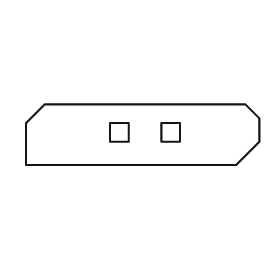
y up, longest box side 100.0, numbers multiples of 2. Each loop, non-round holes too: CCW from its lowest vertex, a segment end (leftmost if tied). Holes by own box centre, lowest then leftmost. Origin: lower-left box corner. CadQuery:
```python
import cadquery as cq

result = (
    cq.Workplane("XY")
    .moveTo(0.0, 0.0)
    .lineTo(90.0, 0.0)
    .lineTo(100.0, 10.0)
    .lineTo(100.0, 20.0)
    .lineTo(94.0, 26.0)
    .lineTo(8.0, 26.0)
    .lineTo(0.0, 18.0)
    .close()
    .moveTo(36.0, 10.0)
    .lineTo(44.0, 10.0)
    .lineTo(44.0, 18.0)
    .lineTo(36.0, 18.0)
    .close()
    .moveTo(58.0, 10.0)
    .lineTo(66.0, 10.0)
    .lineTo(66.0, 18.0)
    .lineTo(58.0, 18.0)
    .close()
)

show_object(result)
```